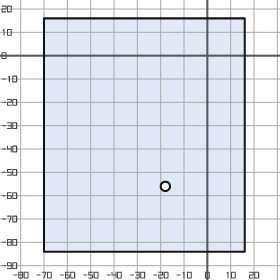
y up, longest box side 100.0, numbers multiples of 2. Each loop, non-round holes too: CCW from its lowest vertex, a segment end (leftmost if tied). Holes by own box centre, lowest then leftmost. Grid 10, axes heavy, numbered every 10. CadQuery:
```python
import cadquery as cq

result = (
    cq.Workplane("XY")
    .moveTo(-70.0, -84.0)
    .lineTo(16.0, -84.0)
    .lineTo(16.0, 16.0)
    .lineTo(-70.0, 16.0)
    .close()
    .moveTo(-18.0, -56.0)
    .circle(2.0)
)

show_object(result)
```